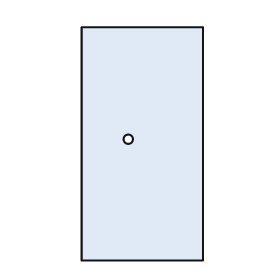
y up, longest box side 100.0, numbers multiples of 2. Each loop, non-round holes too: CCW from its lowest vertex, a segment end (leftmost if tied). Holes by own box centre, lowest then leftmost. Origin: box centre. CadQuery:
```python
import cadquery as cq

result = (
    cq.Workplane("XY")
    .moveTo(-26.0, -50.0)
    .lineTo(26.0, -50.0)
    .lineTo(26.0, 50.0)
    .lineTo(-26.0, 50.0)
    .close()
    .moveTo(-6.0, 2.0)
    .circle(2.0)
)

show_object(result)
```